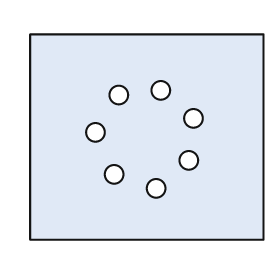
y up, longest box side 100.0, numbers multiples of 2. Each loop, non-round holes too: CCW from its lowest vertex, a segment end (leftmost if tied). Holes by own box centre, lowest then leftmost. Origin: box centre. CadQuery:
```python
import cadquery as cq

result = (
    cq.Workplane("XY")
    .moveTo(-50.0, -44.0)
    .lineTo(50.0, -44.0)
    .lineTo(50.0, 44.0)
    .lineTo(-50.0, 44.0)
    .close()
    .moveTo(4.0, -22.0)
    .circle(4.0)
    .moveTo(-14.0, -16.0)
    .circle(4.0)
    .moveTo(18.0, -10.0)
    .circle(4.0)
    .moveTo(-22.0, 2.0)
    .circle(4.0)
    .moveTo(20.0, 8.0)
    .circle(4.0)
    .moveTo(-12.0, 18.0)
    .circle(4.0)
    .moveTo(6.0, 20.0)
    .circle(4.0)
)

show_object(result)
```